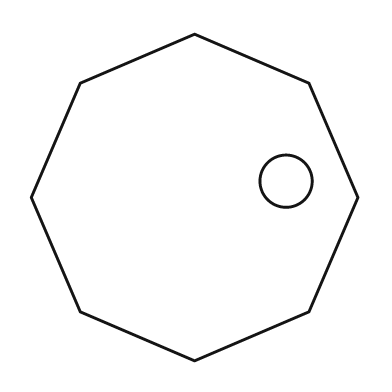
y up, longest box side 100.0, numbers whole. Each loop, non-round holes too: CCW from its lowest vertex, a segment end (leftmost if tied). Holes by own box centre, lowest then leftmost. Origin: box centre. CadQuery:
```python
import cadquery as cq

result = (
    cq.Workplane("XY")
    .moveTo(0.0, -50.0)
    .lineTo(35.0, -35.0)
    .lineTo(50.0, 0.0)
    .lineTo(35.0, 35.0)
    .lineTo(0.0, 50.0)
    .lineTo(-35.0, 35.0)
    .lineTo(-50.0, 0.0)
    .lineTo(-35.0, -35.0)
    .close()
    .moveTo(28.0, 5.0)
    .circle(8.0)
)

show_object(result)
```